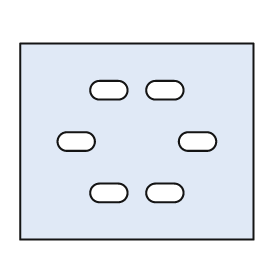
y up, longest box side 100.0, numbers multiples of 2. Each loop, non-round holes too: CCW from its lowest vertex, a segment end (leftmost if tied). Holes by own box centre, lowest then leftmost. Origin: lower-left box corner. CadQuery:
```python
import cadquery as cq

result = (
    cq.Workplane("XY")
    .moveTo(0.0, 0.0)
    .lineTo(100.0, 0.0)
    .lineTo(100.0, 84.0)
    .lineTo(0.0, 84.0)
    .close()
    .moveTo(34.0, 16.0)
    .lineTo(42.0, 16.0)
    .threePointArc((46.0, 20.0), (42.0, 24.0))
    .lineTo(34.0, 24.0)
    .threePointArc((30.0, 20.0), (34.0, 16.0))
    .close()
    .moveTo(58.0, 16.0)
    .lineTo(66.0, 16.0)
    .threePointArc((70.0, 20.0), (66.0, 24.0))
    .lineTo(58.0, 24.0)
    .threePointArc((54.0, 20.0), (58.0, 16.0))
    .close()
    .moveTo(20.0, 38.0)
    .lineTo(28.0, 38.0)
    .threePointArc((32.0, 42.0), (28.0, 46.0))
    .lineTo(20.0, 46.0)
    .threePointArc((16.0, 42.0), (20.0, 38.0))
    .close()
    .moveTo(72.0, 38.0)
    .lineTo(80.0, 38.0)
    .threePointArc((84.0, 42.0), (80.0, 46.0))
    .lineTo(72.0, 46.0)
    .threePointArc((68.0, 42.0), (72.0, 38.0))
    .close()
    .moveTo(34.0, 60.0)
    .lineTo(42.0, 60.0)
    .threePointArc((46.0, 64.0), (42.0, 68.0))
    .lineTo(34.0, 68.0)
    .threePointArc((30.0, 64.0), (34.0, 60.0))
    .close()
    .moveTo(58.0, 60.0)
    .lineTo(66.0, 60.0)
    .threePointArc((70.0, 64.0), (66.0, 68.0))
    .lineTo(58.0, 68.0)
    .threePointArc((54.0, 64.0), (58.0, 60.0))
    .close()
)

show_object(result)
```